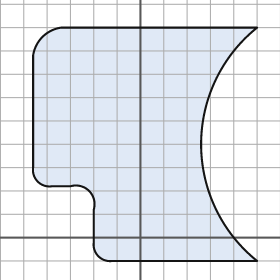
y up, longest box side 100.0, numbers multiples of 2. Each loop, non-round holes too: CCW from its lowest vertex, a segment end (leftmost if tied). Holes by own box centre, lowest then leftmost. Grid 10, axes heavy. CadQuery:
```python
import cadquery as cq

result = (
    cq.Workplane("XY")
    .moveTo(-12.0, -10.0)
    .lineTo(50.0, -10.0)
    .threePointArc((26.0, 40.0), (50.0, 90.0))
    .lineTo(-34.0, 90.0)
    .threePointArc((-42.0, 86.0), (-46.0, 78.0))
    .lineTo(-46.0, 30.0)
    .threePointArc((-44.0, 24.0), (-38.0, 22.0))
    .lineTo(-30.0, 22.0)
    .threePointArc((-22.0, 20.0), (-20.0, 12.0))
    .lineTo(-20.0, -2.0)
    .threePointArc((-18.0, -8.0), (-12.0, -10.0))
    .close()
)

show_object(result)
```